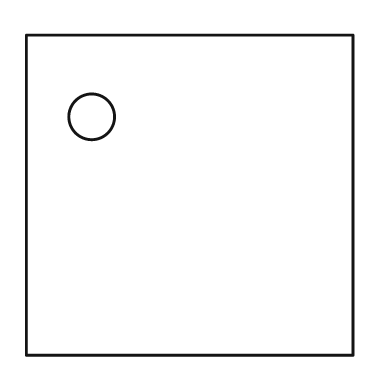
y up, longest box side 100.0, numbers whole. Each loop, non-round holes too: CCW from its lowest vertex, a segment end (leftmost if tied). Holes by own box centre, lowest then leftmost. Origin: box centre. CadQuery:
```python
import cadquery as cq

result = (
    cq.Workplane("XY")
    .moveTo(-50.0, -49.0)
    .lineTo(50.0, -49.0)
    .lineTo(50.0, 49.0)
    .lineTo(-50.0, 49.0)
    .close()
    .moveTo(-30.0, 24.0)
    .circle(7.0)
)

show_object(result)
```